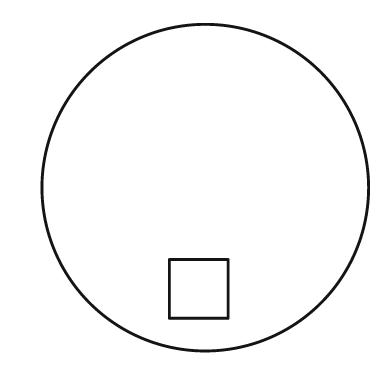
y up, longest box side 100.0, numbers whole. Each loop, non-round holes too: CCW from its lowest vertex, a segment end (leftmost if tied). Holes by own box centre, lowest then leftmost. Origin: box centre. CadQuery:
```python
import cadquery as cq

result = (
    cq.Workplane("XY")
    .moveTo(0.0, 0.0)
    .circle(50.0)
    .moveTo(-11.0, -40.0)
    .lineTo(7.0, -40.0)
    .lineTo(7.0, -22.0)
    .lineTo(-11.0, -22.0)
    .close()
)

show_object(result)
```